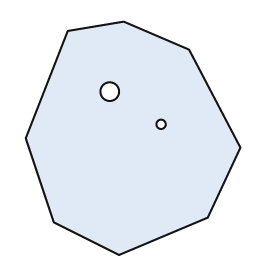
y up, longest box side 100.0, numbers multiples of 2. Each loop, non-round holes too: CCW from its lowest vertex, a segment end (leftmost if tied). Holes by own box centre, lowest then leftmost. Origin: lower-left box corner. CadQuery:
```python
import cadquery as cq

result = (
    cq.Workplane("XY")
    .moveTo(40.0, 0.0)
    .lineTo(78.0, 16.0)
    .lineTo(92.0, 46.0)
    .lineTo(70.0, 88.0)
    .lineTo(42.0, 100.0)
    .lineTo(18.0, 96.0)
    .lineTo(0.0, 50.0)
    .lineTo(12.0, 14.0)
    .close()
    .moveTo(58.0, 56.0)
    .circle(2.0)
    .moveTo(36.0, 70.0)
    .circle(4.0)
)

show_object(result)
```